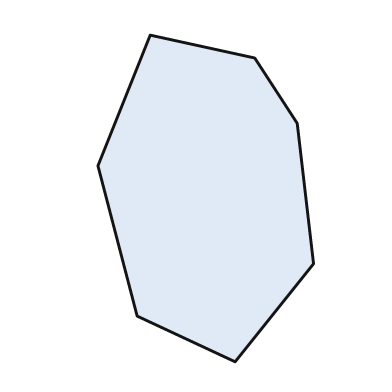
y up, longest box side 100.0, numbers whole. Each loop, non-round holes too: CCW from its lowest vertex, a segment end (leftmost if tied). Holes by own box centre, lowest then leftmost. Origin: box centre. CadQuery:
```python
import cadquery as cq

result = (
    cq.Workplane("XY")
    .moveTo(9.0, -50.0)
    .lineTo(33.0, -20.0)
    .lineTo(28.0, 23.0)
    .lineTo(15.0, 43.0)
    .lineTo(-17.0, 50.0)
    .lineTo(-33.0, 10.0)
    .lineTo(-21.0, -36.0)
    .close()
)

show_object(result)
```